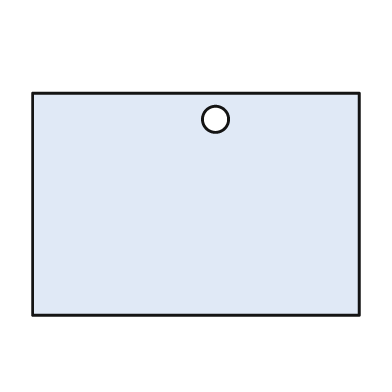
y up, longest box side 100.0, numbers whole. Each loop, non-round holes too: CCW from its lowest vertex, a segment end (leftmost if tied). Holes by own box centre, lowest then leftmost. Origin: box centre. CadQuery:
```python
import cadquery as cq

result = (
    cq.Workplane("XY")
    .moveTo(-50.0, -34.0)
    .lineTo(50.0, -34.0)
    .lineTo(50.0, 34.0)
    .lineTo(-50.0, 34.0)
    .close()
    .moveTo(6.0, 26.0)
    .circle(4.0)
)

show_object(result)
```